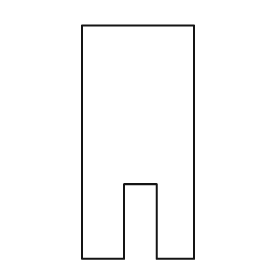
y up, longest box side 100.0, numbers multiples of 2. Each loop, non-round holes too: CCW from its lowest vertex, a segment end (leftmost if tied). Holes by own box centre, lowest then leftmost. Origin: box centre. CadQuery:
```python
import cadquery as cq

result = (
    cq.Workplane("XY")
    .moveTo(-24.0, -50.0)
    .lineTo(-6.0, -50.0)
    .lineTo(-6.0, -18.0)
    .lineTo(8.0, -18.0)
    .lineTo(8.0, -50.0)
    .lineTo(24.0, -50.0)
    .lineTo(24.0, 50.0)
    .lineTo(-24.0, 50.0)
    .close()
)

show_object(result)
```